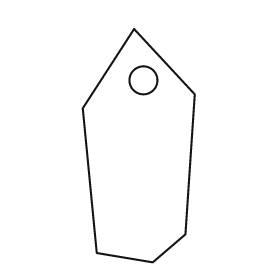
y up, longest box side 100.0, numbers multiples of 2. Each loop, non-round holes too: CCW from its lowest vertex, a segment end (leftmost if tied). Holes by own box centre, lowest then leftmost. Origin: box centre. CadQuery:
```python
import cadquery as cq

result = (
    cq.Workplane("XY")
    .moveTo(6.0, -50.0)
    .lineTo(20.0, -38.0)
    .lineTo(24.0, 22.0)
    .lineTo(-2.0, 50.0)
    .lineTo(-24.0, 16.0)
    .lineTo(-18.0, -46.0)
    .close()
    .moveTo(2.0, 28.0)
    .circle(6.0)
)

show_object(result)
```